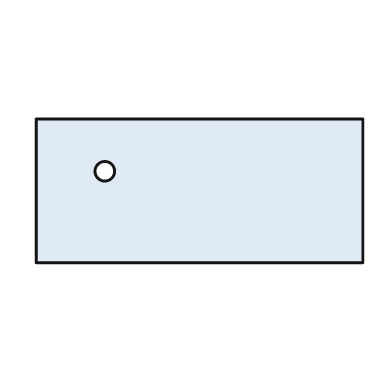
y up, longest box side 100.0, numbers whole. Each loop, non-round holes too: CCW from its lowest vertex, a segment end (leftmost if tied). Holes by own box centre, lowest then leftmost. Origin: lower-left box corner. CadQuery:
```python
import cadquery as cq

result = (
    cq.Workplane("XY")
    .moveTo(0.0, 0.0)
    .lineTo(100.0, 0.0)
    .lineTo(100.0, 44.0)
    .lineTo(0.0, 44.0)
    .close()
    .moveTo(21.0, 28.0)
    .circle(3.0)
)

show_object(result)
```